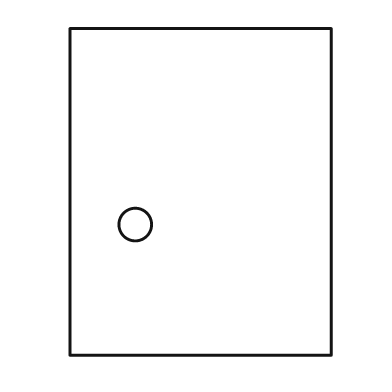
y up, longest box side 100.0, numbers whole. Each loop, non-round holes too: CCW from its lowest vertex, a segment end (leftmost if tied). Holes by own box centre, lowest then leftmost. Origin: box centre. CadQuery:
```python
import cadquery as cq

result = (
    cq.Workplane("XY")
    .moveTo(-40.0, -50.0)
    .lineTo(40.0, -50.0)
    .lineTo(40.0, 50.0)
    .lineTo(-40.0, 50.0)
    .close()
    .moveTo(-20.0, -10.0)
    .circle(5.0)
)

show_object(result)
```